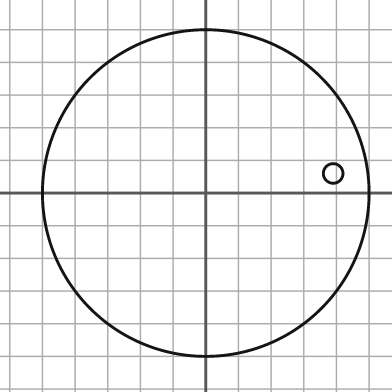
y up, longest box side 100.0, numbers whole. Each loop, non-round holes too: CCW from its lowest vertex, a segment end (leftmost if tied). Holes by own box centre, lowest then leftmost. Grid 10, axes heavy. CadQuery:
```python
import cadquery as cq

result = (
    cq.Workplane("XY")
    .moveTo(0.0, 0.0)
    .circle(50.0)
    .moveTo(39.0, 6.0)
    .circle(3.0)
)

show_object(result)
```